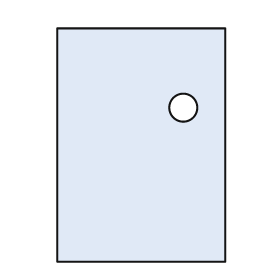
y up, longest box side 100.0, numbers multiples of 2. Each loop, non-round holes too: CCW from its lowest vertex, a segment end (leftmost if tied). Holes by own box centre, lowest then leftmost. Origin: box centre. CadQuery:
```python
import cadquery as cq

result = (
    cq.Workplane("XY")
    .moveTo(-36.0, -50.0)
    .lineTo(36.0, -50.0)
    .lineTo(36.0, 50.0)
    .lineTo(-36.0, 50.0)
    .close()
    .moveTo(18.0, 16.0)
    .circle(6.0)
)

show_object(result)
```